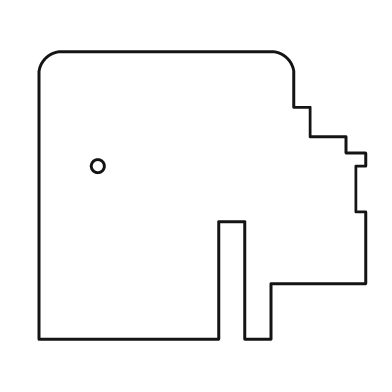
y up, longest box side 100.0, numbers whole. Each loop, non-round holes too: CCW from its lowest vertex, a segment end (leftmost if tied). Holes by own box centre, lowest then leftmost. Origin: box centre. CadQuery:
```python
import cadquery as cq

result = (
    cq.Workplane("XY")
    .moveTo(-50.0, -44.0)
    .lineTo(5.0, -44.0)
    .lineTo(5.0, -8.0)
    .lineTo(13.0, -8.0)
    .lineTo(13.0, -44.0)
    .lineTo(21.0, -44.0)
    .lineTo(21.0, -27.0)
    .lineTo(50.0, -27.0)
    .lineTo(50.0, -5.0)
    .lineTo(47.0, -5.0)
    .lineTo(47.0, 9.0)
    .lineTo(50.0, 9.0)
    .lineTo(50.0, 13.0)
    .lineTo(44.0, 13.0)
    .lineTo(44.0, 18.0)
    .lineTo(33.0, 18.0)
    .lineTo(33.0, 27.0)
    .lineTo(28.0, 27.0)
    .lineTo(28.0, 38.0)
    .threePointArc((26.0, 42.0), (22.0, 44.0))
    .lineTo(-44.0, 44.0)
    .threePointArc((-48.0, 42.0), (-50.0, 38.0))
    .close()
    .moveTo(-32.0, 9.0)
    .circle(2.0)
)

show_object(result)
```